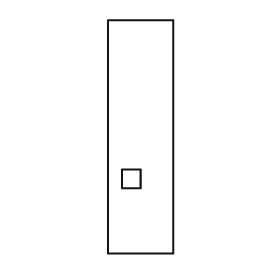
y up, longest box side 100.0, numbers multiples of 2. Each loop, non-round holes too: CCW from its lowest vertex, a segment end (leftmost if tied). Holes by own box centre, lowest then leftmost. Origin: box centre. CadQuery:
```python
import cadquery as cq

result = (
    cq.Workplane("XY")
    .moveTo(-14.0, -50.0)
    .lineTo(14.0, -50.0)
    .lineTo(14.0, 50.0)
    .lineTo(-14.0, 50.0)
    .close()
    .moveTo(-8.0, -22.0)
    .lineTo(0.0, -22.0)
    .lineTo(0.0, -14.0)
    .lineTo(-8.0, -14.0)
    .close()
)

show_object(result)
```